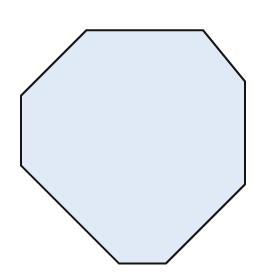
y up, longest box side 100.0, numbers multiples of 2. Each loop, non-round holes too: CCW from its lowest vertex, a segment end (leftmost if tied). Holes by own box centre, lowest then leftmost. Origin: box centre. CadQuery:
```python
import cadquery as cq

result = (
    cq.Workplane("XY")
    .moveTo(-6.0, -50.0)
    .lineTo(14.0, -50.0)
    .lineTo(48.0, -16.0)
    .lineTo(48.0, 28.0)
    .lineTo(30.0, 50.0)
    .lineTo(-20.0, 50.0)
    .lineTo(-48.0, 22.0)
    .lineTo(-48.0, -8.0)
    .close()
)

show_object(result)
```